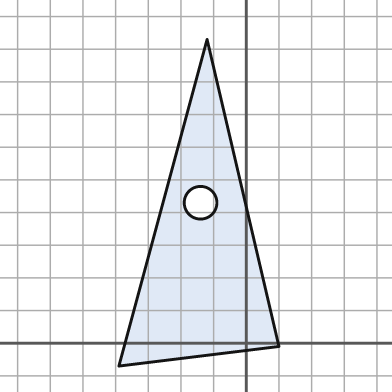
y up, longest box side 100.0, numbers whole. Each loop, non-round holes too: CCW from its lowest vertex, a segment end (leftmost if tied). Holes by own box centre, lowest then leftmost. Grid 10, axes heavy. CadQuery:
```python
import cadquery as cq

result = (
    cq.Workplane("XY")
    .moveTo(-39.0, -7.0)
    .lineTo(10.0, -1.0)
    .lineTo(-12.0, 93.0)
    .close()
    .moveTo(-14.0, 43.0)
    .circle(5.0)
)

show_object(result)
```